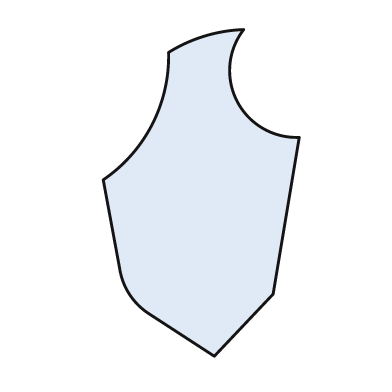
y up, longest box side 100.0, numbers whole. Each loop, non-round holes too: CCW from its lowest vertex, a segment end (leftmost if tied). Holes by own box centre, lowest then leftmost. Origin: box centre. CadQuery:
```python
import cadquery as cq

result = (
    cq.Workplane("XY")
    .moveTo(4.0, -50.0)
    .lineTo(22.0, -31.0)
    .lineTo(30.0, 17.0)
    .threePointArc((11.0, 28.0), (13.0, 50.0))
    .threePointArc((1.0, 48.0), (-10.0, 43.0))
    .threePointArc((-15.0, 21.0), (-30.0, 4.0))
    .lineTo(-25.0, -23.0)
    .threePointArc((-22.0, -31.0), (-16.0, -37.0))
    .close()
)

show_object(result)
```